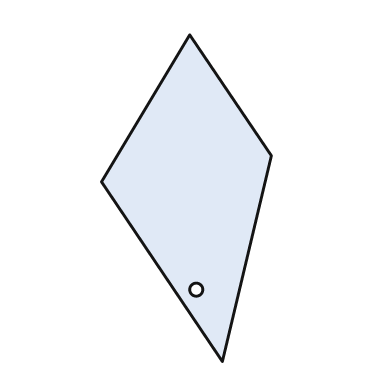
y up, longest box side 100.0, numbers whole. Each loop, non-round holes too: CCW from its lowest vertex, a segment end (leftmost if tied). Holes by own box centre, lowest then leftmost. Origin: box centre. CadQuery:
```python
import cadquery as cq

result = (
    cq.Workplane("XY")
    .moveTo(11.0, -50.0)
    .lineTo(26.0, 13.0)
    .lineTo(1.0, 50.0)
    .lineTo(-26.0, 5.0)
    .close()
    .moveTo(3.0, -28.0)
    .circle(2.0)
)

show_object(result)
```